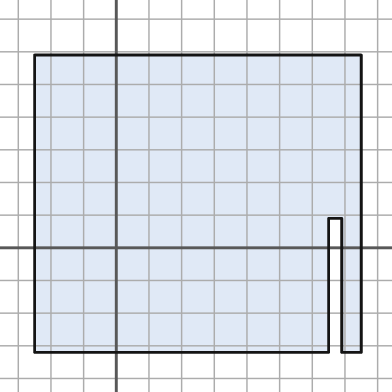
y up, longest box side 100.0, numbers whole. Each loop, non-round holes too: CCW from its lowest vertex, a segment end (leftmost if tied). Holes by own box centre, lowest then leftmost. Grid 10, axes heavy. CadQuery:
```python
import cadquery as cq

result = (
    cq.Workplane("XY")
    .moveTo(-25.0, -32.0)
    .lineTo(65.0, -32.0)
    .lineTo(65.0, 9.0)
    .lineTo(69.0, 9.0)
    .lineTo(69.0, -32.0)
    .lineTo(75.0, -32.0)
    .lineTo(75.0, 59.0)
    .lineTo(-25.0, 59.0)
    .close()
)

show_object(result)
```